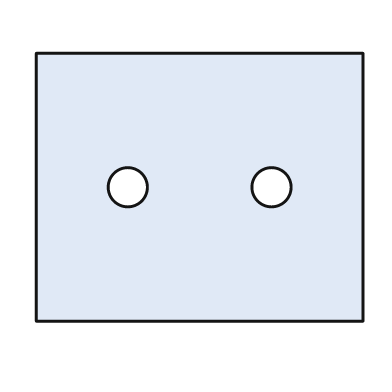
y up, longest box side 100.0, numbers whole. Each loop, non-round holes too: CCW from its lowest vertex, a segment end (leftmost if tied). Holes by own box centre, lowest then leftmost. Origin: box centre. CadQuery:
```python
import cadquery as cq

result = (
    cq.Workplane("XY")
    .moveTo(-50.0, -41.0)
    .lineTo(50.0, -41.0)
    .lineTo(50.0, 41.0)
    .lineTo(-50.0, 41.0)
    .close()
    .moveTo(-22.0, 0.0)
    .circle(6.0)
    .moveTo(22.0, 0.0)
    .circle(6.0)
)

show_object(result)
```